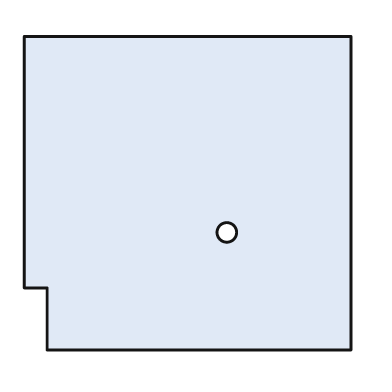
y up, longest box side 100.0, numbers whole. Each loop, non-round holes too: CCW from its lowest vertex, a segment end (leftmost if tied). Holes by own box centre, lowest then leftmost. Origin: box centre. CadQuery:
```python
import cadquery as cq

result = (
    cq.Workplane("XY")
    .moveTo(-43.0, -48.0)
    .lineTo(50.0, -48.0)
    .lineTo(50.0, 48.0)
    .lineTo(-50.0, 48.0)
    .lineTo(-50.0, -29.0)
    .lineTo(-43.0, -29.0)
    .close()
    .moveTo(12.0, -12.0)
    .circle(3.0)
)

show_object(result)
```